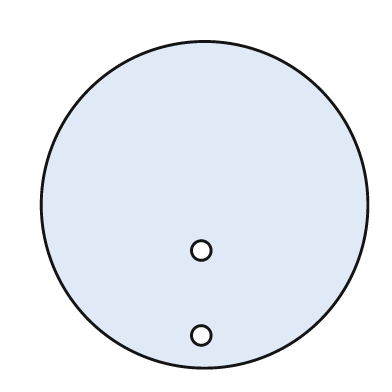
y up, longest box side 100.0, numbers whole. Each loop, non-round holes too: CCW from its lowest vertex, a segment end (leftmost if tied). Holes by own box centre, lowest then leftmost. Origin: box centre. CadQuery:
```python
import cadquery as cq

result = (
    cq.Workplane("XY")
    .moveTo(0.0, 0.0)
    .circle(50.0)
    .moveTo(-1.0, -40.0)
    .circle(3.0)
    .moveTo(-1.0, -14.0)
    .circle(3.0)
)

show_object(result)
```